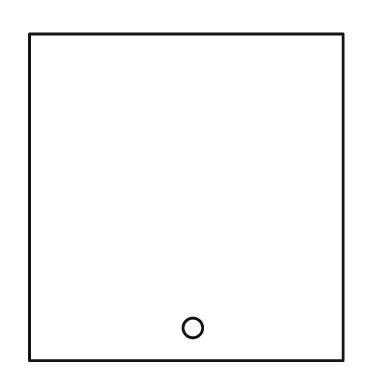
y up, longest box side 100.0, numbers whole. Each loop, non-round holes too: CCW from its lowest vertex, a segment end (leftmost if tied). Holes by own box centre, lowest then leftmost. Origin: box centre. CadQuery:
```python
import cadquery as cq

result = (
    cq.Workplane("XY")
    .moveTo(-48.0, -50.0)
    .lineTo(48.0, -50.0)
    .lineTo(48.0, 50.0)
    .lineTo(-48.0, 50.0)
    .close()
    .moveTo(2.0, -40.0)
    .circle(3.0)
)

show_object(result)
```